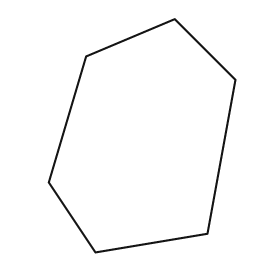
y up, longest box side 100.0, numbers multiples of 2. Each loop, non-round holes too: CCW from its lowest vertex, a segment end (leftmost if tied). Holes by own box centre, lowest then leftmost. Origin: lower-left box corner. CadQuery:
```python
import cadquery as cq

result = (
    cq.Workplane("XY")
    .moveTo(20.0, 0.0)
    .lineTo(68.0, 8.0)
    .lineTo(80.0, 74.0)
    .lineTo(54.0, 100.0)
    .lineTo(16.0, 84.0)
    .lineTo(0.0, 30.0)
    .close()
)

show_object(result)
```